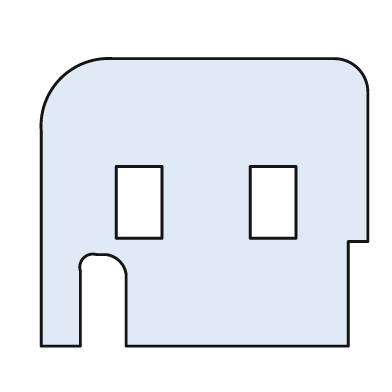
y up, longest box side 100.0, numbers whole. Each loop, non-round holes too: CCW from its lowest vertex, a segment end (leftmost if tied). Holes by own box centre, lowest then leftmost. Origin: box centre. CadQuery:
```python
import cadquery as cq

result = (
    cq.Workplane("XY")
    .moveTo(-50.0, -44.0)
    .lineTo(-38.0, -44.0)
    .lineTo(-38.0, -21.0)
    .threePointArc((-37.0, -17.0), (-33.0, -16.0))
    .lineTo(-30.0, -16.0)
    .threePointArc((-26.0, -18.0), (-24.0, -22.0))
    .lineTo(-24.0, -44.0)
    .lineTo(44.0, -44.0)
    .lineTo(44.0, -12.0)
    .lineTo(50.0, -12.0)
    .lineTo(50.0, 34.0)
    .threePointArc((47.0, 41.0), (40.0, 44.0))
    .lineTo(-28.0, 44.0)
    .threePointArc((-44.0, 38.0), (-50.0, 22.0))
    .close()
    .moveTo(-27.0, -11.0)
    .lineTo(-13.0, -11.0)
    .lineTo(-13.0, 11.0)
    .lineTo(-27.0, 11.0)
    .close()
    .moveTo(14.0, -11.0)
    .lineTo(28.0, -11.0)
    .lineTo(28.0, 11.0)
    .lineTo(14.0, 11.0)
    .close()
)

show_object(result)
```